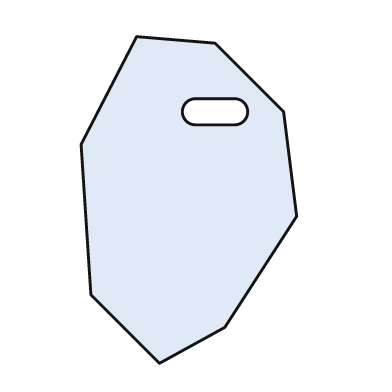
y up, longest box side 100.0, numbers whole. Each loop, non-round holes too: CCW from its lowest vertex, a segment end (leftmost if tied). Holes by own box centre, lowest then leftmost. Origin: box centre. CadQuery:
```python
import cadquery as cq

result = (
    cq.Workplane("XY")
    .moveTo(-9.0, -50.0)
    .lineTo(11.0, -39.0)
    .lineTo(33.0, -5.0)
    .lineTo(29.0, 27.0)
    .lineTo(8.0, 48.0)
    .lineTo(-16.0, 50.0)
    .lineTo(-33.0, 17.0)
    .lineTo(-30.0, -29.0)
    .close()
    .moveTo(2.0, 23.0)
    .lineTo(14.0, 23.0)
    .threePointArc((18.0, 27.0), (14.0, 31.0))
    .lineTo(2.0, 31.0)
    .threePointArc((-2.0, 27.0), (2.0, 23.0))
    .close()
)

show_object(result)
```